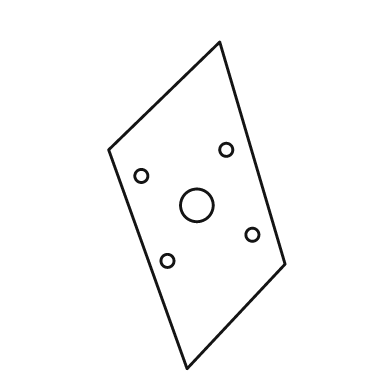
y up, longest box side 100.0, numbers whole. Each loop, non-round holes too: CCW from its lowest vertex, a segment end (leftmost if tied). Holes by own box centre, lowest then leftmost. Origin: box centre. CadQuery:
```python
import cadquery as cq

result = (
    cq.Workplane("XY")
    .moveTo(-3.0, -50.0)
    .lineTo(27.0, -18.0)
    .lineTo(7.0, 50.0)
    .lineTo(-27.0, 17.0)
    .close()
    .moveTo(-9.0, -17.0)
    .circle(2.0)
    .moveTo(17.0, -9.0)
    .circle(2.0)
    .moveTo(0.0, 0.0)
    .circle(5.0)
    .moveTo(-17.0, 9.0)
    .circle(2.0)
    .moveTo(9.0, 17.0)
    .circle(2.0)
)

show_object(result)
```